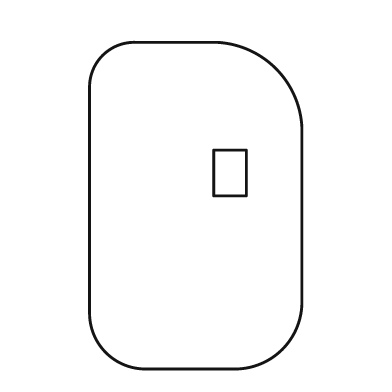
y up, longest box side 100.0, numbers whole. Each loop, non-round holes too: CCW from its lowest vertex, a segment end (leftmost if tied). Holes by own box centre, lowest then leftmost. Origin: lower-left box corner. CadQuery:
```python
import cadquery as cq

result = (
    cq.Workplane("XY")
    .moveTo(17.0, 0.0)
    .lineTo(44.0, 0.0)
    .threePointArc((59.0, 6.0), (65.0, 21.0))
    .lineTo(65.0, 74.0)
    .threePointArc((57.0, 92.0), (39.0, 100.0))
    .lineTo(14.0, 100.0)
    .threePointArc((4.0, 96.0), (0.0, 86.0))
    .lineTo(0.0, 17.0)
    .threePointArc((5.0, 5.0), (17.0, 0.0))
    .close()
    .moveTo(38.0, 53.0)
    .lineTo(48.0, 53.0)
    .lineTo(48.0, 67.0)
    .lineTo(38.0, 67.0)
    .close()
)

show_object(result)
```